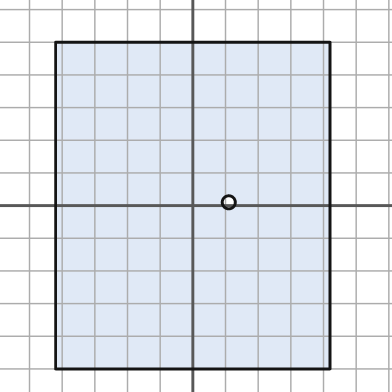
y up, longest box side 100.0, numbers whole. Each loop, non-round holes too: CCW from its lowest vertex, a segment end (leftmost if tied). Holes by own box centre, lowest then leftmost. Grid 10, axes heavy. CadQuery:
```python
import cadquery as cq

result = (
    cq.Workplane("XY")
    .moveTo(-42.0, -50.0)
    .lineTo(42.0, -50.0)
    .lineTo(42.0, 50.0)
    .lineTo(-42.0, 50.0)
    .close()
    .moveTo(11.0, 1.0)
    .circle(2.0)
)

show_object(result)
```